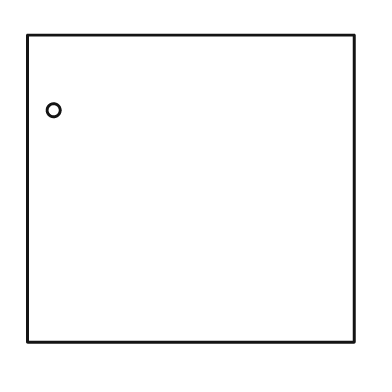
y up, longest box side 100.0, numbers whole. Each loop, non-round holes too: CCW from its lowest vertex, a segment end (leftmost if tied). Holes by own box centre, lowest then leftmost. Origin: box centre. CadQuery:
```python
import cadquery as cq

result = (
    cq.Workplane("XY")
    .moveTo(-50.0, -47.0)
    .lineTo(50.0, -47.0)
    .lineTo(50.0, 47.0)
    .lineTo(-50.0, 47.0)
    .close()
    .moveTo(-42.0, 24.0)
    .circle(2.0)
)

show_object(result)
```